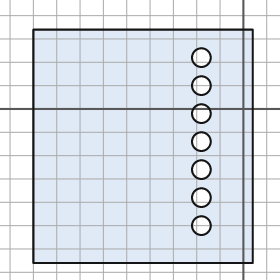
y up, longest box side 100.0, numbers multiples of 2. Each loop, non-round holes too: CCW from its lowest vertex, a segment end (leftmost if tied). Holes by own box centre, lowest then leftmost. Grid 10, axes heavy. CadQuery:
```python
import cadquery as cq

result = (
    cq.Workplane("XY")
    .moveTo(-90.0, -66.0)
    .lineTo(4.0, -66.0)
    .lineTo(4.0, 34.0)
    .lineTo(-90.0, 34.0)
    .close()
    .moveTo(-18.0, -50.0)
    .circle(4.0)
    .moveTo(-18.0, -38.0)
    .circle(4.0)
    .moveTo(-18.0, -26.0)
    .circle(4.0)
    .moveTo(-18.0, -14.0)
    .circle(4.0)
    .moveTo(-18.0, -2.0)
    .circle(4.0)
    .moveTo(-18.0, 10.0)
    .circle(4.0)
    .moveTo(-18.0, 22.0)
    .circle(4.0)
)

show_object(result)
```